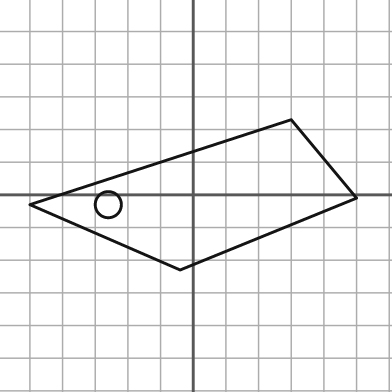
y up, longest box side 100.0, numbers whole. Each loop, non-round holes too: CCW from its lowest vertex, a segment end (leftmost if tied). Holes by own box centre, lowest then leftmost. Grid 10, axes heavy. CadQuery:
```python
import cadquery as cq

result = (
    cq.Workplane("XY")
    .moveTo(-4.0, -23.0)
    .lineTo(50.0, -1.0)
    .lineTo(30.0, 23.0)
    .lineTo(-50.0, -3.0)
    .close()
    .moveTo(-26.0, -3.0)
    .circle(4.0)
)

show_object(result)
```